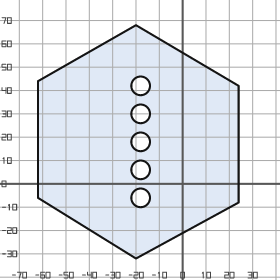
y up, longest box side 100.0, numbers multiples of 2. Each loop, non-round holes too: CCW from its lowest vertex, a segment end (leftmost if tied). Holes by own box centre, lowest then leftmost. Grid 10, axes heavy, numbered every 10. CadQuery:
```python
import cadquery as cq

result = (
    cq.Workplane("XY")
    .moveTo(-20.0, -32.0)
    .lineTo(24.0, -8.0)
    .lineTo(24.0, 42.0)
    .lineTo(-20.0, 68.0)
    .lineTo(-62.0, 44.0)
    .lineTo(-62.0, -6.0)
    .close()
    .moveTo(-18.0, -6.0)
    .circle(4.0)
    .moveTo(-18.0, 6.0)
    .circle(4.0)
    .moveTo(-18.0, 18.0)
    .circle(4.0)
    .moveTo(-18.0, 30.0)
    .circle(4.0)
    .moveTo(-18.0, 42.0)
    .circle(4.0)
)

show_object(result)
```